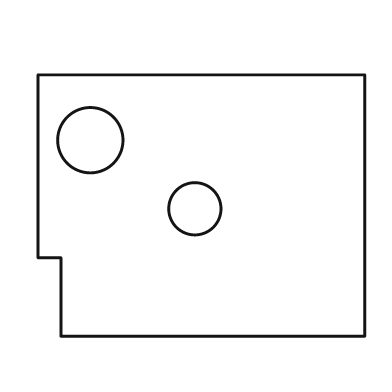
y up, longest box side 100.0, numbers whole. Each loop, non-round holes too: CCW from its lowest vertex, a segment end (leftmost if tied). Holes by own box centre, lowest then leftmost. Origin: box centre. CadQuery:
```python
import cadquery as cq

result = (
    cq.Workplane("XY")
    .moveTo(-43.0, -40.0)
    .lineTo(50.0, -40.0)
    .lineTo(50.0, 40.0)
    .lineTo(-50.0, 40.0)
    .lineTo(-50.0, -16.0)
    .lineTo(-43.0, -16.0)
    .close()
    .moveTo(-2.0, -1.0)
    .circle(8.0)
    .moveTo(-34.0, 20.0)
    .circle(10.0)
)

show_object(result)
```